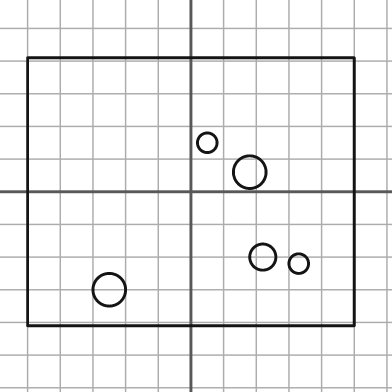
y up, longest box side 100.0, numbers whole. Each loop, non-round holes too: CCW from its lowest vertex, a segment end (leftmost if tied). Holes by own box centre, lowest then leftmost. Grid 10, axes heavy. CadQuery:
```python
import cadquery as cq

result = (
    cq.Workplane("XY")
    .moveTo(-50.0, -41.0)
    .lineTo(50.0, -41.0)
    .lineTo(50.0, 41.0)
    .lineTo(-50.0, 41.0)
    .close()
    .moveTo(-25.0, -30.0)
    .circle(5.0)
    .moveTo(33.0, -22.0)
    .circle(3.0)
    .moveTo(22.0, -20.0)
    .circle(4.0)
    .moveTo(18.0, 6.0)
    .circle(5.0)
    .moveTo(5.0, 15.0)
    .circle(3.0)
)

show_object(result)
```